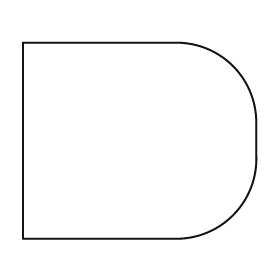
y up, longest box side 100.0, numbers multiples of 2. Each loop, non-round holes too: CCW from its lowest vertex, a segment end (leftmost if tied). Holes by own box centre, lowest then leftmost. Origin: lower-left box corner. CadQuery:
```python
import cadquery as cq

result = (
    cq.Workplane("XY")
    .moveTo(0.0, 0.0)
    .lineTo(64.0, 0.0)
    .threePointArc((90.0, 10.0), (100.0, 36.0))
    .lineTo(100.0, 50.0)
    .threePointArc((90.0, 74.0), (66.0, 84.0))
    .lineTo(0.0, 84.0)
    .close()
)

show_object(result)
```